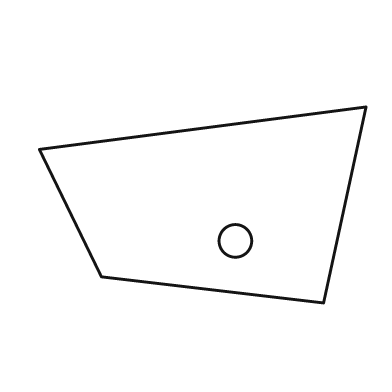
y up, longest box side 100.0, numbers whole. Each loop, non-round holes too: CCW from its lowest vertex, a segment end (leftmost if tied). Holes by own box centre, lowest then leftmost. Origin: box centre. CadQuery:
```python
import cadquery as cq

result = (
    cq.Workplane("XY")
    .moveTo(37.0, -30.0)
    .lineTo(50.0, 30.0)
    .lineTo(-50.0, 17.0)
    .lineTo(-31.0, -22.0)
    .close()
    .moveTo(10.0, -11.0)
    .circle(5.0)
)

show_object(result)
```